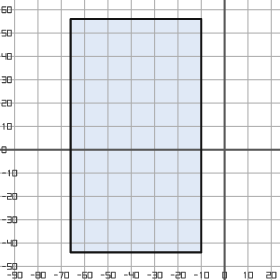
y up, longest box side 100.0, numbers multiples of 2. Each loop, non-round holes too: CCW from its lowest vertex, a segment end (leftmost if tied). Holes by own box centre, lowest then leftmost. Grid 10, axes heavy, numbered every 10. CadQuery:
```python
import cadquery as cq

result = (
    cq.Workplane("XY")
    .moveTo(-66.0, -44.0)
    .lineTo(-10.0, -44.0)
    .lineTo(-10.0, 56.0)
    .lineTo(-66.0, 56.0)
    .close()
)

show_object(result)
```